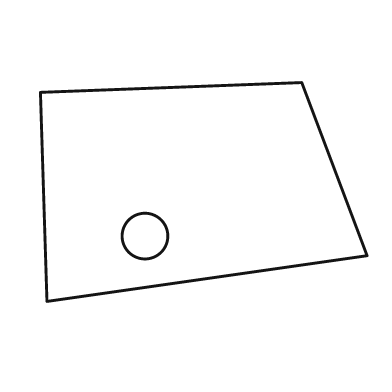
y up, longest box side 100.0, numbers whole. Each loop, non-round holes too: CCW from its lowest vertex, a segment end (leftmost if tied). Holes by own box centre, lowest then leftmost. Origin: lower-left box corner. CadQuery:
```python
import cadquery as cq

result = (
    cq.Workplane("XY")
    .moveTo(2.0, 0.0)
    .lineTo(100.0, 14.0)
    .lineTo(80.0, 67.0)
    .lineTo(0.0, 64.0)
    .close()
    .moveTo(32.0, 20.0)
    .circle(7.0)
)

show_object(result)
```